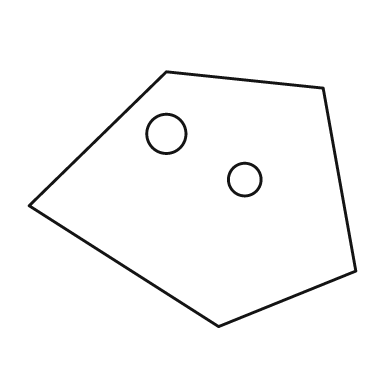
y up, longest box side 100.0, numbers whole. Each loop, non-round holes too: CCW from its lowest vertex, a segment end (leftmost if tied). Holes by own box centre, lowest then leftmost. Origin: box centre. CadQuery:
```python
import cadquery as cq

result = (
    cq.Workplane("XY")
    .moveTo(8.0, -39.0)
    .lineTo(50.0, -22.0)
    .lineTo(40.0, 34.0)
    .lineTo(-8.0, 39.0)
    .lineTo(-50.0, -2.0)
    .close()
    .moveTo(16.0, 6.0)
    .circle(5.0)
    .moveTo(-8.0, 20.0)
    .circle(6.0)
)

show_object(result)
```